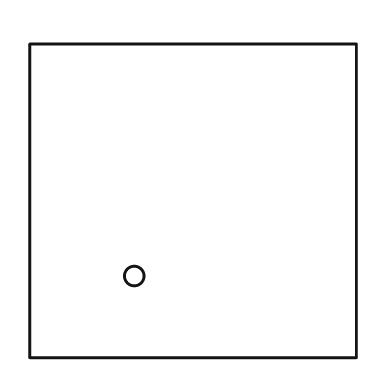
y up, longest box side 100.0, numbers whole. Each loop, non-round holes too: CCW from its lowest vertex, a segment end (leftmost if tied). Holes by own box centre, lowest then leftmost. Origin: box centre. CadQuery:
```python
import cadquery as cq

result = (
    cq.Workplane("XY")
    .moveTo(-50.0, -48.0)
    .lineTo(50.0, -48.0)
    .lineTo(50.0, 48.0)
    .lineTo(-50.0, 48.0)
    .close()
    .moveTo(-18.0, -23.0)
    .circle(3.0)
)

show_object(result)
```